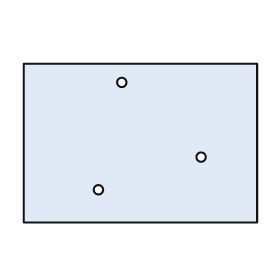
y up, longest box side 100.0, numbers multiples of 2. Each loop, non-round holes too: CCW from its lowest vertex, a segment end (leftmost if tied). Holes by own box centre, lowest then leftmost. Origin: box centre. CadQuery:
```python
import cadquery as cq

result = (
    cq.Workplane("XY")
    .moveTo(-50.0, -34.0)
    .lineTo(50.0, -34.0)
    .lineTo(50.0, 34.0)
    .lineTo(-50.0, 34.0)
    .close()
    .moveTo(-18.0, -20.0)
    .circle(2.0)
    .moveTo(26.0, -6.0)
    .circle(2.0)
    .moveTo(-8.0, 26.0)
    .circle(2.0)
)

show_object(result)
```